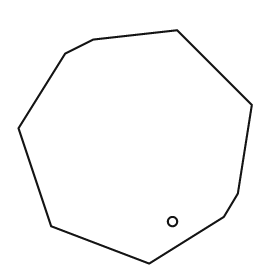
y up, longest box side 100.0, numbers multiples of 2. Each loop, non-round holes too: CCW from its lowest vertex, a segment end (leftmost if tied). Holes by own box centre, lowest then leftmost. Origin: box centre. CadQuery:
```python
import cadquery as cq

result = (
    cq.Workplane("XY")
    .moveTo(6.0, -50.0)
    .lineTo(38.0, -30.0)
    .lineTo(44.0, -20.0)
    .lineTo(50.0, 18.0)
    .lineTo(18.0, 50.0)
    .lineTo(-18.0, 46.0)
    .lineTo(-30.0, 40.0)
    .lineTo(-50.0, 8.0)
    .lineTo(-36.0, -34.0)
    .close()
    .moveTo(16.0, -32.0)
    .circle(2.0)
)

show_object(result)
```